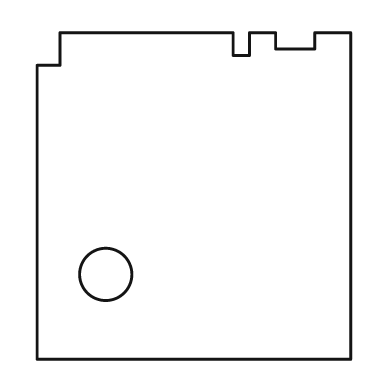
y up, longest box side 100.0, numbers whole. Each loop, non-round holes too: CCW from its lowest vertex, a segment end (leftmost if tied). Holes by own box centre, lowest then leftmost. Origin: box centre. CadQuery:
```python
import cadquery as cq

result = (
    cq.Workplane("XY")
    .moveTo(-48.0, -50.0)
    .lineTo(48.0, -50.0)
    .lineTo(48.0, 50.0)
    .lineTo(37.0, 50.0)
    .lineTo(37.0, 45.0)
    .lineTo(25.0, 45.0)
    .lineTo(25.0, 50.0)
    .lineTo(17.0, 50.0)
    .lineTo(17.0, 43.0)
    .lineTo(12.0, 43.0)
    .lineTo(12.0, 50.0)
    .lineTo(-41.0, 50.0)
    .lineTo(-41.0, 40.0)
    .lineTo(-48.0, 40.0)
    .close()
    .moveTo(-27.0, -24.0)
    .circle(8.0)
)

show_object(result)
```